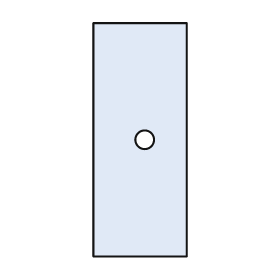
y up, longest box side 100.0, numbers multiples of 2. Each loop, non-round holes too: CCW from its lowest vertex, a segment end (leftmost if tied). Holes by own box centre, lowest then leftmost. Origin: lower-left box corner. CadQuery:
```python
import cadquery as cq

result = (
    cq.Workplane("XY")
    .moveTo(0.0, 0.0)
    .lineTo(40.0, 0.0)
    .lineTo(40.0, 100.0)
    .lineTo(0.0, 100.0)
    .close()
    .moveTo(22.0, 50.0)
    .circle(4.0)
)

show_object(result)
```